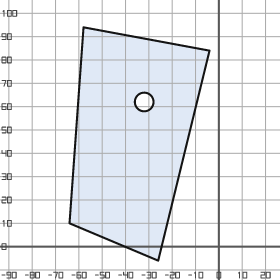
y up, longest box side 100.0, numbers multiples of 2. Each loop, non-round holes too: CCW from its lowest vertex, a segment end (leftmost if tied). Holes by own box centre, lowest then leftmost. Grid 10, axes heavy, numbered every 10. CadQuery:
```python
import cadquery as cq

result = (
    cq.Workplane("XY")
    .moveTo(-26.0, -6.0)
    .lineTo(-4.0, 84.0)
    .lineTo(-58.0, 94.0)
    .lineTo(-64.0, 10.0)
    .close()
    .moveTo(-32.0, 62.0)
    .circle(4.0)
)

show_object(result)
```